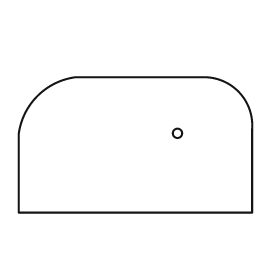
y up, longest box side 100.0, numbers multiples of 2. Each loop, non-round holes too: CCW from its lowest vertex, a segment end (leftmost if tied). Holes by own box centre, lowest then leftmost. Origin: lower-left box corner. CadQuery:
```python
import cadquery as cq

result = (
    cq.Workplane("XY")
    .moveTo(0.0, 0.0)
    .lineTo(100.0, 0.0)
    .lineTo(100.0, 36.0)
    .threePointArc((94.0, 52.0), (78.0, 58.0))
    .lineTo(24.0, 58.0)
    .threePointArc((8.0, 50.0), (0.0, 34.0))
    .close()
    .moveTo(68.0, 34.0)
    .circle(2.0)
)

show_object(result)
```